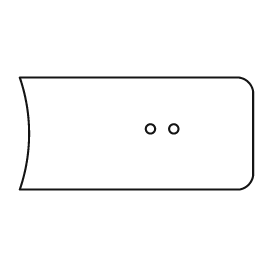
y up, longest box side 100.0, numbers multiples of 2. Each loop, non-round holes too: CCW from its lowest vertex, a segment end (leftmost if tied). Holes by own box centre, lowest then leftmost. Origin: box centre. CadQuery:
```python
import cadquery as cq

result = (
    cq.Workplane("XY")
    .moveTo(-50.0, -24.0)
    .lineTo(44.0, -24.0)
    .threePointArc((48.0, -22.0), (50.0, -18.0))
    .lineTo(50.0, 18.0)
    .threePointArc((48.0, 22.0), (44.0, 24.0))
    .lineTo(-50.0, 24.0)
    .threePointArc((-46.0, 0.0), (-50.0, -24.0))
    .close()
    .moveTo(6.0, 2.0)
    .circle(2.0)
    .moveTo(16.0, 2.0)
    .circle(2.0)
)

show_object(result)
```